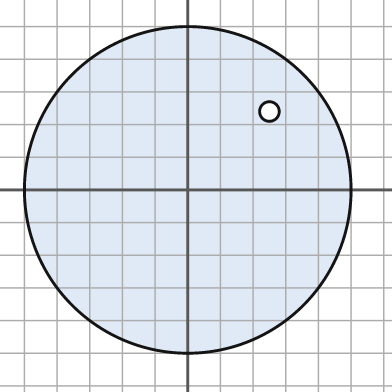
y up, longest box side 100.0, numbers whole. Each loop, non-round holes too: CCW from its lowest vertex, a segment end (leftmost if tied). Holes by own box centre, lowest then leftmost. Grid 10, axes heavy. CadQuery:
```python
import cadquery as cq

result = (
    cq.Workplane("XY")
    .moveTo(0.0, 0.0)
    .circle(50.0)
    .moveTo(25.0, 24.0)
    .circle(3.0)
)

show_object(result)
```